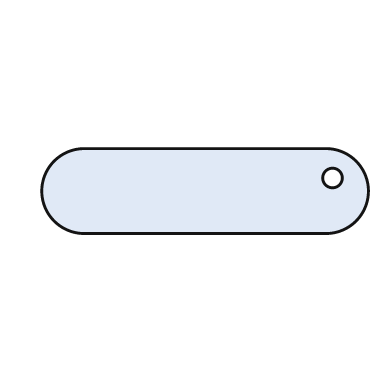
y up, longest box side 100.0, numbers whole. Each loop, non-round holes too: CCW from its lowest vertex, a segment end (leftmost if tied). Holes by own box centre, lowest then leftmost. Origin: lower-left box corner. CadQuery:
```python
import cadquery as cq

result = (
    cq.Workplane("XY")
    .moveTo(13.0, 0.0)
    .lineTo(87.0, 0.0)
    .threePointArc((100.0, 13.0), (87.0, 26.0))
    .lineTo(13.0, 26.0)
    .threePointArc((0.0, 13.0), (13.0, 0.0))
    .close()
    .moveTo(89.0, 17.0)
    .circle(3.0)
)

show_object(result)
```